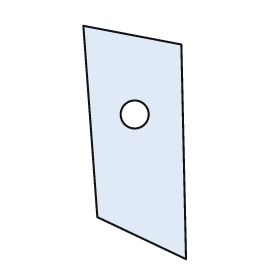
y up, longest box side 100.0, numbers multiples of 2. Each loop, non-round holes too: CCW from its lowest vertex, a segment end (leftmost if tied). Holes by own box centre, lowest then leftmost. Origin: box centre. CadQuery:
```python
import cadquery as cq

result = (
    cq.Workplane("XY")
    .moveTo(22.0, -50.0)
    .lineTo(20.0, 42.0)
    .lineTo(-22.0, 50.0)
    .lineTo(-16.0, -32.0)
    .close()
    .moveTo(0.0, 12.0)
    .circle(6.0)
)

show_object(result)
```